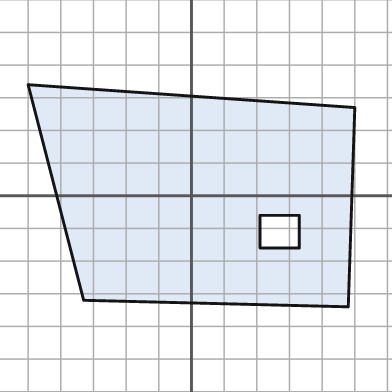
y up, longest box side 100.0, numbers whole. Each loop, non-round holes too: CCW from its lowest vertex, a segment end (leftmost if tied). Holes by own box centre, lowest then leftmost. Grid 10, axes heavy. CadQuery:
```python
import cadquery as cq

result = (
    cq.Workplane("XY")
    .moveTo(48.0, -34.0)
    .lineTo(50.0, 27.0)
    .lineTo(-50.0, 34.0)
    .lineTo(-33.0, -32.0)
    .close()
    .moveTo(21.0, -16.0)
    .lineTo(33.0, -16.0)
    .lineTo(33.0, -6.0)
    .lineTo(21.0, -6.0)
    .close()
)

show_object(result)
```